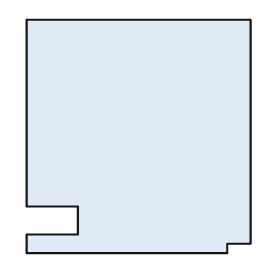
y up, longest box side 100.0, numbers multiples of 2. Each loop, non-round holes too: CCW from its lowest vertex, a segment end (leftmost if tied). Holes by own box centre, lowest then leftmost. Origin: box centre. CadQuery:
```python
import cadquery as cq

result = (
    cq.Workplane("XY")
    .moveTo(-48.0, -50.0)
    .lineTo(38.0, -50.0)
    .lineTo(38.0, -46.0)
    .lineTo(48.0, -46.0)
    .lineTo(48.0, 50.0)
    .lineTo(-48.0, 50.0)
    .lineTo(-48.0, -30.0)
    .lineTo(-26.0, -30.0)
    .lineTo(-26.0, -42.0)
    .lineTo(-48.0, -42.0)
    .close()
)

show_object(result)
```